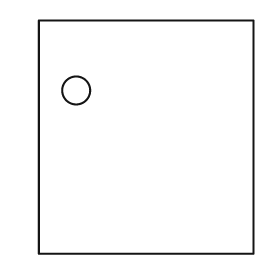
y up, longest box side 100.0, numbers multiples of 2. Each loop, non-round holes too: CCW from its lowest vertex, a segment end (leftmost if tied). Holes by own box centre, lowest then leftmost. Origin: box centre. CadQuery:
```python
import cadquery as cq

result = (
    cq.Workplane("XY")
    .moveTo(-46.0, -50.0)
    .lineTo(46.0, -50.0)
    .lineTo(46.0, 50.0)
    .lineTo(-46.0, 50.0)
    .close()
    .moveTo(-30.0, 20.0)
    .circle(6.0)
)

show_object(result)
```